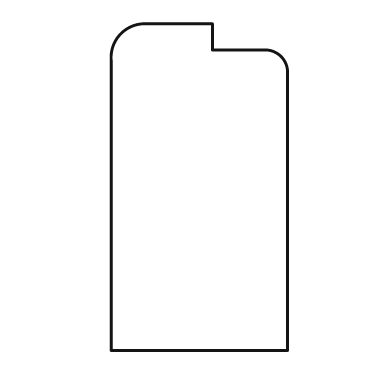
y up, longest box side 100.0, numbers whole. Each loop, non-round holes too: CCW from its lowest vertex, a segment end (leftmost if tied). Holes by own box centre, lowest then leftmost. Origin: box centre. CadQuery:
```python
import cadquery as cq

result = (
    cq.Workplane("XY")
    .moveTo(-27.0, -50.0)
    .lineTo(27.0, -50.0)
    .lineTo(27.0, 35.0)
    .threePointArc((25.0, 40.0), (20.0, 42.0))
    .lineTo(4.0, 42.0)
    .lineTo(4.0, 50.0)
    .lineTo(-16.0, 50.0)
    .threePointArc((-24.0, 47.0), (-27.0, 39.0))
    .close()
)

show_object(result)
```